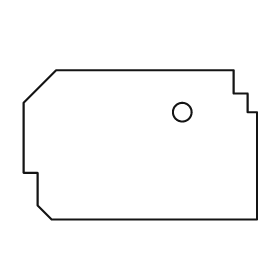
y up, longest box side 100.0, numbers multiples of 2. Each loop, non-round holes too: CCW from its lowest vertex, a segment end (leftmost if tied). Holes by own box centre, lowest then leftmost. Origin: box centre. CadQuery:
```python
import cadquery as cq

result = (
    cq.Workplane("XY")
    .moveTo(-38.0, -32.0)
    .lineTo(50.0, -32.0)
    .lineTo(50.0, 14.0)
    .lineTo(46.0, 14.0)
    .lineTo(46.0, 22.0)
    .lineTo(40.0, 22.0)
    .lineTo(40.0, 32.0)
    .lineTo(-36.0, 32.0)
    .lineTo(-50.0, 18.0)
    .lineTo(-50.0, -12.0)
    .lineTo(-44.0, -12.0)
    .lineTo(-44.0, -26.0)
    .close()
    .moveTo(18.0, 14.0)
    .circle(4.0)
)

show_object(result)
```